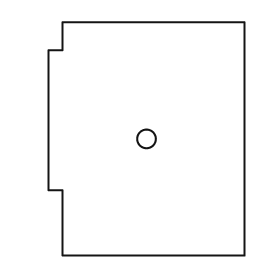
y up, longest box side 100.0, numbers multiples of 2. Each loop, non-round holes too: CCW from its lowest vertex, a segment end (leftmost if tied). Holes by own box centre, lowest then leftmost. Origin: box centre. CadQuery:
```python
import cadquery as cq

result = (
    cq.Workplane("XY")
    .moveTo(-36.0, -50.0)
    .lineTo(42.0, -50.0)
    .lineTo(42.0, 50.0)
    .lineTo(-36.0, 50.0)
    .lineTo(-36.0, 38.0)
    .lineTo(-42.0, 38.0)
    .lineTo(-42.0, -22.0)
    .lineTo(-36.0, -22.0)
    .close()
    .moveTo(0.0, 0.0)
    .circle(4.0)
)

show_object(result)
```